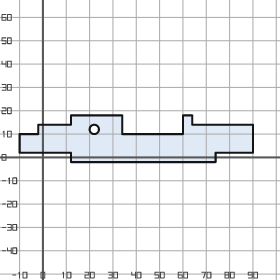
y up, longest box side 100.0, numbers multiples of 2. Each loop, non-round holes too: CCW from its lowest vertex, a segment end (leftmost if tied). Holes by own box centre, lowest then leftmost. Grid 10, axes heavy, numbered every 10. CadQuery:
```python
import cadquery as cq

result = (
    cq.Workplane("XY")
    .moveTo(12.0, -2.0)
    .lineTo(74.0, -2.0)
    .lineTo(74.0, 2.0)
    .lineTo(90.0, 2.0)
    .lineTo(90.0, 14.0)
    .lineTo(64.0, 14.0)
    .lineTo(64.0, 18.0)
    .lineTo(60.0, 18.0)
    .lineTo(60.0, 10.0)
    .lineTo(34.0, 10.0)
    .lineTo(34.0, 18.0)
    .lineTo(12.0, 18.0)
    .lineTo(12.0, 14.0)
    .lineTo(-2.0, 14.0)
    .lineTo(-2.0, 10.0)
    .lineTo(-10.0, 10.0)
    .lineTo(-10.0, 2.0)
    .lineTo(12.0, 2.0)
    .close()
    .moveTo(22.0, 12.0)
    .circle(2.0)
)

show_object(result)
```